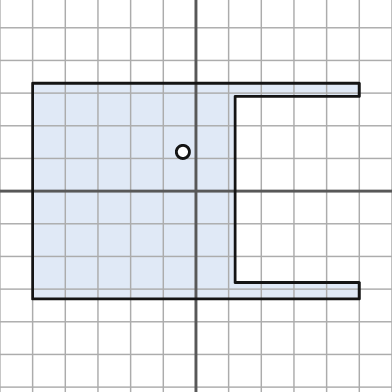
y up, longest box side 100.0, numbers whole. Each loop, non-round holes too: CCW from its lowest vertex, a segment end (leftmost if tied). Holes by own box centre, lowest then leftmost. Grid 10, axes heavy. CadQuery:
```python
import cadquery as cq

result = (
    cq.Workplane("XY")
    .moveTo(-50.0, -33.0)
    .lineTo(50.0, -33.0)
    .lineTo(50.0, -28.0)
    .lineTo(12.0, -28.0)
    .lineTo(12.0, 29.0)
    .lineTo(50.0, 29.0)
    .lineTo(50.0, 33.0)
    .lineTo(-50.0, 33.0)
    .close()
    .moveTo(-4.0, 12.0)
    .circle(2.0)
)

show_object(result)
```